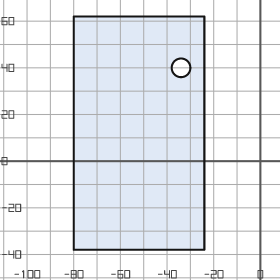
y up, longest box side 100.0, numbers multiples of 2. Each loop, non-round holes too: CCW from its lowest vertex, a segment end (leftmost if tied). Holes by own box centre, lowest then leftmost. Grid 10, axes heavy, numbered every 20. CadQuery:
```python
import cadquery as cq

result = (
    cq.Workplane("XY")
    .moveTo(-80.0, -38.0)
    .lineTo(-24.0, -38.0)
    .lineTo(-24.0, 62.0)
    .lineTo(-80.0, 62.0)
    .close()
    .moveTo(-34.0, 40.0)
    .circle(4.0)
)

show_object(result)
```